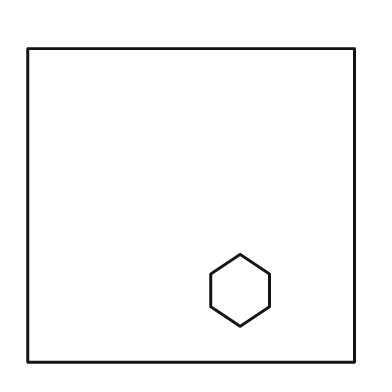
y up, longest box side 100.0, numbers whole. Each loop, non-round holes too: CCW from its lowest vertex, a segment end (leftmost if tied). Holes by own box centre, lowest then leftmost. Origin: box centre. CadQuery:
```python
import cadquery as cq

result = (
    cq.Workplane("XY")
    .moveTo(-50.0, -48.0)
    .lineTo(50.0, -48.0)
    .lineTo(50.0, 48.0)
    .lineTo(-50.0, 48.0)
    .close()
    .moveTo(15.0, -37.0)
    .lineTo(24.0, -31.0)
    .lineTo(24.0, -21.0)
    .lineTo(15.0, -15.0)
    .lineTo(6.0, -21.0)
    .lineTo(6.0, -31.0)
    .close()
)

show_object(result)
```